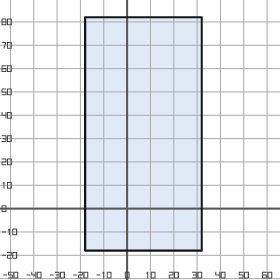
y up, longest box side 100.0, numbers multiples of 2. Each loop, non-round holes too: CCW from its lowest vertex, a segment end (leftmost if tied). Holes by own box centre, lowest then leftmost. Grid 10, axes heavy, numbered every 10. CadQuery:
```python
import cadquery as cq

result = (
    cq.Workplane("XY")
    .moveTo(-18.0, -18.0)
    .lineTo(32.0, -18.0)
    .lineTo(32.0, 82.0)
    .lineTo(-18.0, 82.0)
    .close()
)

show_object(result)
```